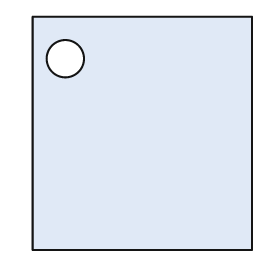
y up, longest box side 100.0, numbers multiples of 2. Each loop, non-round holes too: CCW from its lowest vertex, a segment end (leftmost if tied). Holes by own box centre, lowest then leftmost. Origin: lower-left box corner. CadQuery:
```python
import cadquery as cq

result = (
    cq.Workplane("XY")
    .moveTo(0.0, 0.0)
    .lineTo(94.0, 0.0)
    .lineTo(94.0, 100.0)
    .lineTo(0.0, 100.0)
    .close()
    .moveTo(14.0, 82.0)
    .circle(8.0)
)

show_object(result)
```